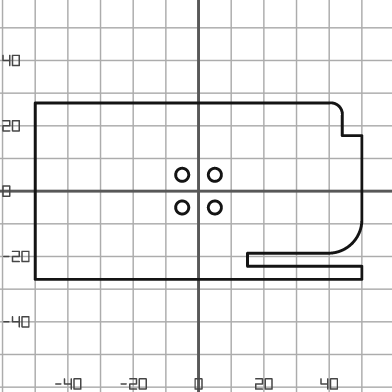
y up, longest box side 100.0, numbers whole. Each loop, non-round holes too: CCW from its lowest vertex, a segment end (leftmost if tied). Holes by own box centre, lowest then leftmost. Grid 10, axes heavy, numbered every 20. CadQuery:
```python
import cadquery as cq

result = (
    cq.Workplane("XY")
    .moveTo(-50.0, -27.0)
    .lineTo(50.0, -27.0)
    .lineTo(50.0, -23.0)
    .lineTo(15.0, -23.0)
    .lineTo(15.0, -19.0)
    .lineTo(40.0, -19.0)
    .threePointArc((47.0, -16.0), (50.0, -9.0))
    .lineTo(50.0, 17.0)
    .lineTo(44.0, 17.0)
    .lineTo(44.0, 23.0)
    .threePointArc((43.0, 26.0), (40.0, 27.0))
    .lineTo(-50.0, 27.0)
    .close()
    .moveTo(-5.0, -5.0)
    .circle(2.0)
    .moveTo(5.0, -5.0)
    .circle(2.0)
    .moveTo(-5.0, 5.0)
    .circle(2.0)
    .moveTo(5.0, 5.0)
    .circle(2.0)
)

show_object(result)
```